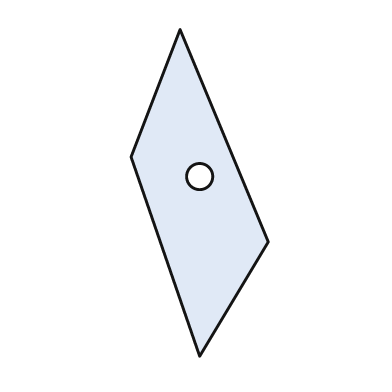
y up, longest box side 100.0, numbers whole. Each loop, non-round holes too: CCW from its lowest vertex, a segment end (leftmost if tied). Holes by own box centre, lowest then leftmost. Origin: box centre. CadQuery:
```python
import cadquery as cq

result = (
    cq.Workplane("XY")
    .moveTo(0.0, -50.0)
    .lineTo(21.0, -15.0)
    .lineTo(-6.0, 50.0)
    .lineTo(-21.0, 11.0)
    .close()
    .moveTo(0.0, 5.0)
    .circle(4.0)
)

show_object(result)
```